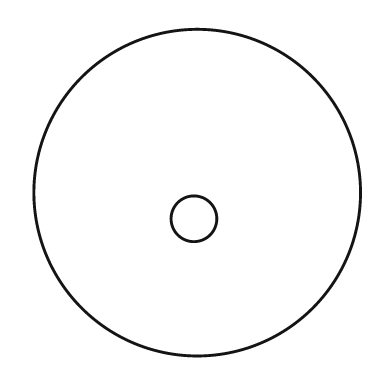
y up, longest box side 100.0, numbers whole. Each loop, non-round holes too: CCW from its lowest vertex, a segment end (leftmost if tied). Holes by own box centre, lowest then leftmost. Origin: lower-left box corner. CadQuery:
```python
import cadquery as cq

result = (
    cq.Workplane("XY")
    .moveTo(50.0, 50.0)
    .circle(50.0)
    .moveTo(49.0, 42.0)
    .circle(7.0)
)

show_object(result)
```